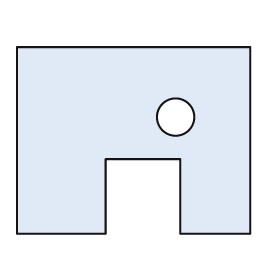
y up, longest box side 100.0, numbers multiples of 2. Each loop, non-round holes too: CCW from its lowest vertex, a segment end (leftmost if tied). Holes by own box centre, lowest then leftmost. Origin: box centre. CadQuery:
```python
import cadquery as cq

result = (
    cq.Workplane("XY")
    .moveTo(-50.0, -40.0)
    .lineTo(-12.0, -40.0)
    .lineTo(-12.0, -8.0)
    .lineTo(20.0, -8.0)
    .lineTo(20.0, -40.0)
    .lineTo(50.0, -40.0)
    .lineTo(50.0, 40.0)
    .lineTo(-50.0, 40.0)
    .close()
    .moveTo(18.0, 10.0)
    .circle(8.0)
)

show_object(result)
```